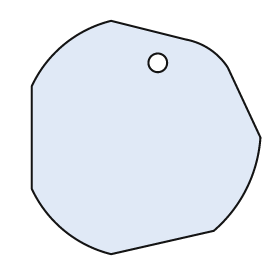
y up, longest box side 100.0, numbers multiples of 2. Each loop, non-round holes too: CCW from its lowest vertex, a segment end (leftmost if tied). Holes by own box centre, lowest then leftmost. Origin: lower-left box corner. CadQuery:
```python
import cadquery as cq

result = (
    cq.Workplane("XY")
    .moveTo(34.0, 0.0)
    .lineTo(78.0, 10.0)
    .threePointArc((92.0, 28.0), (98.0, 50.0))
    .lineTo(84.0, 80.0)
    .threePointArc((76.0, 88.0), (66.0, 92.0))
    .lineTo(34.0, 100.0)
    .threePointArc((14.0, 90.0), (0.0, 72.0))
    .lineTo(0.0, 28.0)
    .threePointArc((14.0, 10.0), (34.0, 0.0))
    .close()
    .moveTo(54.0, 82.0)
    .circle(4.0)
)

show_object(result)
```